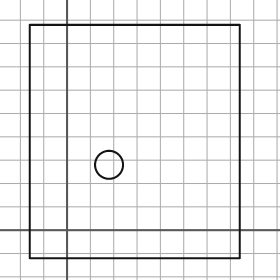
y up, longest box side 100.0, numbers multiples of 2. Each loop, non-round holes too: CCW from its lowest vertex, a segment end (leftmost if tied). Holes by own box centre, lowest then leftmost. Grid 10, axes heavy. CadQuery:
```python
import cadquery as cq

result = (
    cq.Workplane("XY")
    .moveTo(-16.0, -12.0)
    .lineTo(74.0, -12.0)
    .lineTo(74.0, 88.0)
    .lineTo(-16.0, 88.0)
    .close()
    .moveTo(18.0, 28.0)
    .circle(6.0)
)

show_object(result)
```